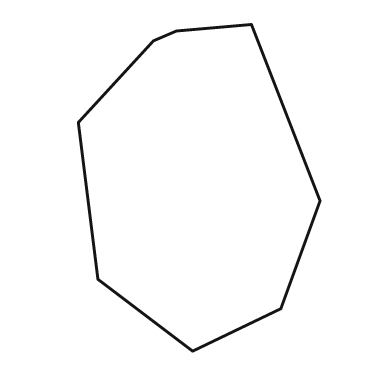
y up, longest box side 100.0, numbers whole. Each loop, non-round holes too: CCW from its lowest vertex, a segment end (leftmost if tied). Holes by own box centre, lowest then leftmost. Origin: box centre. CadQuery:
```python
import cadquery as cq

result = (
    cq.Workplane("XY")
    .moveTo(-2.0, -50.0)
    .lineTo(25.0, -37.0)
    .lineTo(37.0, -4.0)
    .lineTo(16.0, 50.0)
    .lineTo(-7.0, 48.0)
    .lineTo(-14.0, 45.0)
    .lineTo(-37.0, 20.0)
    .lineTo(-31.0, -28.0)
    .close()
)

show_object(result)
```